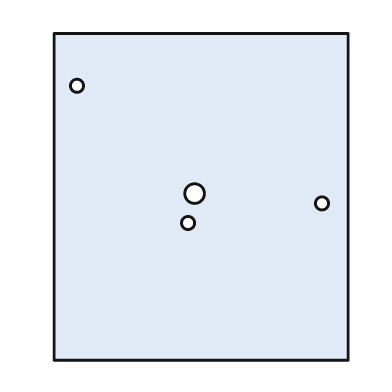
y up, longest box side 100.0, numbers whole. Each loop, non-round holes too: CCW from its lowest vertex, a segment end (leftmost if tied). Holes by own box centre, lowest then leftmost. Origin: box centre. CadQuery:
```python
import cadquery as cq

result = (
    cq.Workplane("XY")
    .moveTo(-45.0, -50.0)
    .lineTo(45.0, -50.0)
    .lineTo(45.0, 50.0)
    .lineTo(-45.0, 50.0)
    .close()
    .moveTo(-4.0, -8.0)
    .circle(2.0)
    .moveTo(37.0, -2.0)
    .circle(2.0)
    .moveTo(-2.0, 1.0)
    .circle(3.0)
    .moveTo(-38.0, 34.0)
    .circle(2.0)
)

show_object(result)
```